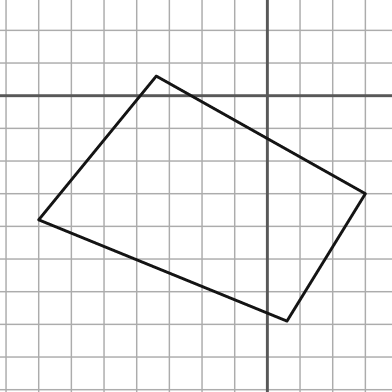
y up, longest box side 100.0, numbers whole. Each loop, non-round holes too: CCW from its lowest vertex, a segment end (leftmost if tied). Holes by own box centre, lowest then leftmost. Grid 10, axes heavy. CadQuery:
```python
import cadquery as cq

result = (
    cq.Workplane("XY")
    .moveTo(6.0, -69.0)
    .lineTo(30.0, -30.0)
    .lineTo(-34.0, 6.0)
    .lineTo(-70.0, -38.0)
    .close()
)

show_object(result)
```